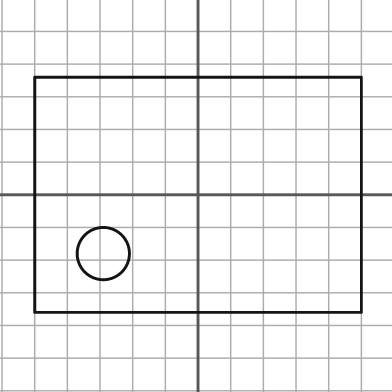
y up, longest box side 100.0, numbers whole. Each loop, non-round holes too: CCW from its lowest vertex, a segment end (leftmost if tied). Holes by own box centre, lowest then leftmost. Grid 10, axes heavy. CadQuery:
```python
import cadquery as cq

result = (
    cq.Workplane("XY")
    .moveTo(-50.0, -36.0)
    .lineTo(50.0, -36.0)
    .lineTo(50.0, 36.0)
    .lineTo(-50.0, 36.0)
    .close()
    .moveTo(-29.0, -18.0)
    .circle(8.0)
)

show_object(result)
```